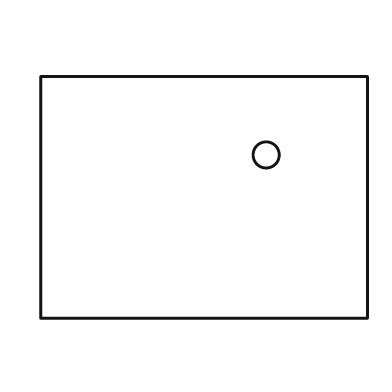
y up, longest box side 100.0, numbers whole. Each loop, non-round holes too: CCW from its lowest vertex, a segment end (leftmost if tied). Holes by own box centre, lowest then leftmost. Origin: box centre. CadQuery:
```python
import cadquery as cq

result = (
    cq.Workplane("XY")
    .moveTo(-50.0, -37.0)
    .lineTo(50.0, -37.0)
    .lineTo(50.0, 37.0)
    .lineTo(-50.0, 37.0)
    .close()
    .moveTo(19.0, 13.0)
    .circle(4.0)
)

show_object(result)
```